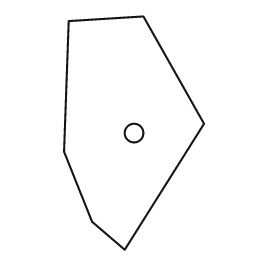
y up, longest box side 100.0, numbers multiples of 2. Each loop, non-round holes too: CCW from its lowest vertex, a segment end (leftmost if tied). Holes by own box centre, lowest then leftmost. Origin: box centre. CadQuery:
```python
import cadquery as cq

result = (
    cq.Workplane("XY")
    .moveTo(-4.0, -50.0)
    .lineTo(30.0, 4.0)
    .lineTo(4.0, 50.0)
    .lineTo(-28.0, 48.0)
    .lineTo(-30.0, -8.0)
    .lineTo(-18.0, -38.0)
    .close()
    .moveTo(0.0, 0.0)
    .circle(4.0)
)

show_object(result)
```